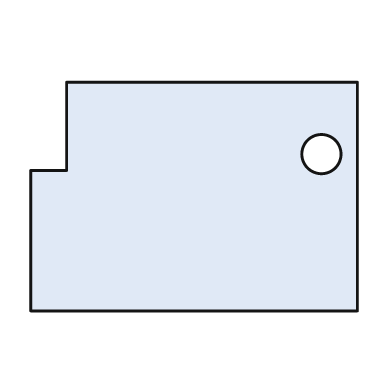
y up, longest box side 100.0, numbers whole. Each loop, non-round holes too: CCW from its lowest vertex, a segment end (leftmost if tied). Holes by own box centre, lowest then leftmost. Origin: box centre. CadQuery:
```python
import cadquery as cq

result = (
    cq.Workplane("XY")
    .moveTo(-50.0, -35.0)
    .lineTo(50.0, -35.0)
    .lineTo(50.0, 35.0)
    .lineTo(-39.0, 35.0)
    .lineTo(-39.0, 8.0)
    .lineTo(-50.0, 8.0)
    .close()
    .moveTo(39.0, 13.0)
    .circle(6.0)
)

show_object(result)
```